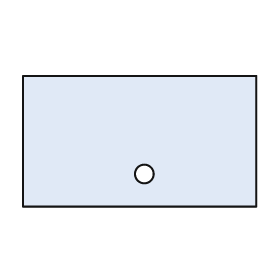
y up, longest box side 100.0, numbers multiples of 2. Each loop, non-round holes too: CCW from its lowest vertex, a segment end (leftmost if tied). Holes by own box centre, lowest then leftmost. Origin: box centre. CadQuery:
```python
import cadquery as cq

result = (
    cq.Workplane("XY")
    .moveTo(-50.0, -28.0)
    .lineTo(50.0, -28.0)
    .lineTo(50.0, 28.0)
    .lineTo(-50.0, 28.0)
    .close()
    .moveTo(2.0, -14.0)
    .circle(4.0)
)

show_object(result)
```